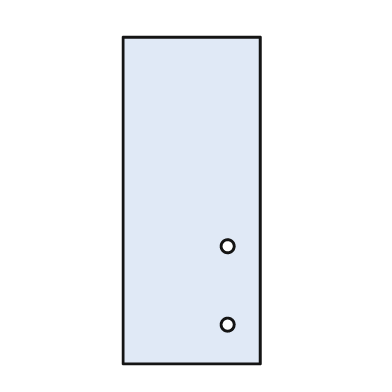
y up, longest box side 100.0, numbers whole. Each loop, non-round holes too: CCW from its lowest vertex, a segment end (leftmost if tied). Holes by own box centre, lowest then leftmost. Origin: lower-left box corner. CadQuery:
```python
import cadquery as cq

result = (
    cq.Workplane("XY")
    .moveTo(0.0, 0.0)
    .lineTo(42.0, 0.0)
    .lineTo(42.0, 100.0)
    .lineTo(0.0, 100.0)
    .close()
    .moveTo(32.0, 12.0)
    .circle(2.0)
    .moveTo(32.0, 36.0)
    .circle(2.0)
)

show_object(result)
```